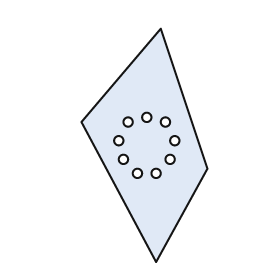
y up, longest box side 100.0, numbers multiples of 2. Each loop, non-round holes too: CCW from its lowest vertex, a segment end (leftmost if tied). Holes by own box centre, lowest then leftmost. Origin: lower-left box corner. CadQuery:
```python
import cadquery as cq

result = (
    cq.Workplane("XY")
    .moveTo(32.0, 0.0)
    .lineTo(54.0, 40.0)
    .lineTo(34.0, 100.0)
    .lineTo(0.0, 60.0)
    .close()
    .moveTo(24.0, 38.0)
    .circle(2.0)
    .moveTo(32.0, 38.0)
    .circle(2.0)
    .moveTo(18.0, 44.0)
    .circle(2.0)
    .moveTo(38.0, 44.0)
    .circle(2.0)
    .moveTo(16.0, 52.0)
    .circle(2.0)
    .moveTo(40.0, 52.0)
    .circle(2.0)
    .moveTo(20.0, 60.0)
    .circle(2.0)
    .moveTo(36.0, 60.0)
    .circle(2.0)
    .moveTo(28.0, 62.0)
    .circle(2.0)
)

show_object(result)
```